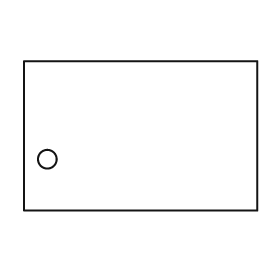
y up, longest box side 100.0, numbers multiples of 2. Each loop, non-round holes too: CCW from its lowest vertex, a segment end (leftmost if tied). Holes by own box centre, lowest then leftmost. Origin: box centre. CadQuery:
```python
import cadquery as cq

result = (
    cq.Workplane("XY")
    .moveTo(-50.0, -32.0)
    .lineTo(50.0, -32.0)
    .lineTo(50.0, 32.0)
    .lineTo(-50.0, 32.0)
    .close()
    .moveTo(-40.0, -10.0)
    .circle(4.0)
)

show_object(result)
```